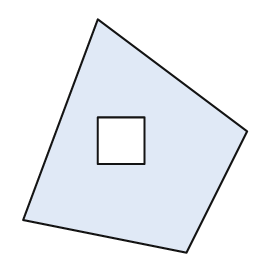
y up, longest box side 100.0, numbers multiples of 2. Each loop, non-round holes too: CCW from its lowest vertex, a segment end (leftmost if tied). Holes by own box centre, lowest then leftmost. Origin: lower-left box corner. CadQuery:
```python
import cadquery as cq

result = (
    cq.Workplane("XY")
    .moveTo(70.0, 0.0)
    .lineTo(96.0, 52.0)
    .lineTo(32.0, 100.0)
    .lineTo(0.0, 14.0)
    .close()
    .moveTo(32.0, 38.0)
    .lineTo(52.0, 38.0)
    .lineTo(52.0, 58.0)
    .lineTo(32.0, 58.0)
    .close()
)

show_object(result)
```